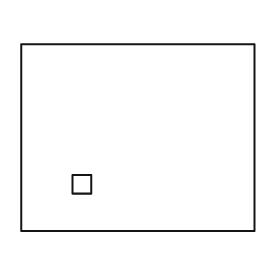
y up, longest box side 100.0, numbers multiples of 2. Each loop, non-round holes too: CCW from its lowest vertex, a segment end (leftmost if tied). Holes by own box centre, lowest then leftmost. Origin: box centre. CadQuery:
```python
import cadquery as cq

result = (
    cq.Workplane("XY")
    .moveTo(-50.0, -40.0)
    .lineTo(50.0, -40.0)
    .lineTo(50.0, 40.0)
    .lineTo(-50.0, 40.0)
    .close()
    .moveTo(-28.0, -24.0)
    .lineTo(-20.0, -24.0)
    .lineTo(-20.0, -16.0)
    .lineTo(-28.0, -16.0)
    .close()
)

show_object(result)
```